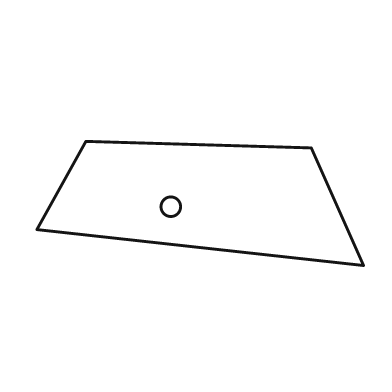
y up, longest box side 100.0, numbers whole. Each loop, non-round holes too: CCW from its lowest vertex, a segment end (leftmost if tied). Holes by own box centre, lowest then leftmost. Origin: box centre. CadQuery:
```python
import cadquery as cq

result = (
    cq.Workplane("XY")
    .moveTo(50.0, -19.0)
    .lineTo(34.0, 17.0)
    .lineTo(-35.0, 19.0)
    .lineTo(-50.0, -8.0)
    .close()
    .moveTo(-9.0, -1.0)
    .circle(3.0)
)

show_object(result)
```